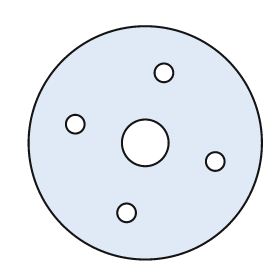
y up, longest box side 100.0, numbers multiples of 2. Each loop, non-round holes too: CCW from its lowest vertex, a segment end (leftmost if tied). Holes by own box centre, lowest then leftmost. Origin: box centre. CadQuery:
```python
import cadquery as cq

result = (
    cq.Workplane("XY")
    .moveTo(0.0, 0.0)
    .circle(50.0)
    .moveTo(-8.0, -30.0)
    .circle(4.0)
    .moveTo(30.0, -8.0)
    .circle(4.0)
    .moveTo(0.0, 0.0)
    .circle(10.0)
    .moveTo(-30.0, 8.0)
    .circle(4.0)
    .moveTo(8.0, 30.0)
    .circle(4.0)
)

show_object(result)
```